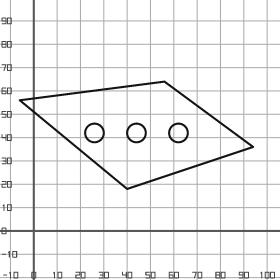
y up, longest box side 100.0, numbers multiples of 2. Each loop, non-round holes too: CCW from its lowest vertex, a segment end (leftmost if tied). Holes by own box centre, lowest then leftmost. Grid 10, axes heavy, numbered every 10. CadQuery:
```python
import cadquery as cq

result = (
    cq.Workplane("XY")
    .moveTo(40.0, 18.0)
    .lineTo(94.0, 36.0)
    .lineTo(56.0, 64.0)
    .lineTo(-6.0, 56.0)
    .close()
    .moveTo(26.0, 42.0)
    .circle(4.0)
    .moveTo(44.0, 42.0)
    .circle(4.0)
    .moveTo(62.0, 42.0)
    .circle(4.0)
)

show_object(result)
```